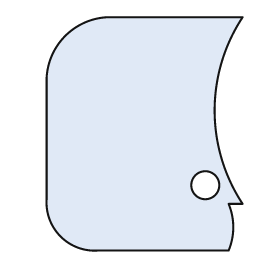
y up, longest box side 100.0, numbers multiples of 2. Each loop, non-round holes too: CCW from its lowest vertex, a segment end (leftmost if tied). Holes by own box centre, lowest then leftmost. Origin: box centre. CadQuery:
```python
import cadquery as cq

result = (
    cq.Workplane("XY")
    .moveTo(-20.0, -50.0)
    .lineTo(36.0, -50.0)
    .threePointArc((38.0, -40.0), (36.0, -30.0))
    .lineTo(42.0, -30.0)
    .threePointArc((30.0, 10.0), (42.0, 50.0))
    .lineTo(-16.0, 50.0)
    .threePointArc((-34.0, 42.0), (-42.0, 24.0))
    .lineTo(-42.0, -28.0)
    .threePointArc((-36.0, -44.0), (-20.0, -50.0))
    .close()
    .moveTo(26.0, -22.0)
    .circle(6.0)
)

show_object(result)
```